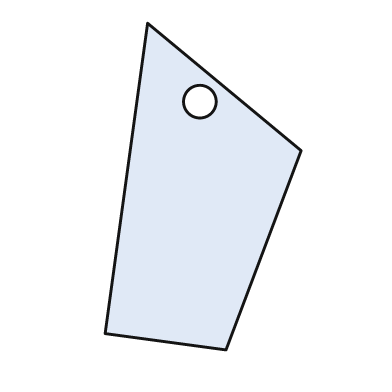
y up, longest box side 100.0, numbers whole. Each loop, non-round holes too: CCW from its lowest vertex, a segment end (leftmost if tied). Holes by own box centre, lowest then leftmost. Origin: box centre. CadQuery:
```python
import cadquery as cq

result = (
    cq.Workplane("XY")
    .moveTo(7.0, -50.0)
    .lineTo(30.0, 11.0)
    .lineTo(-17.0, 50.0)
    .lineTo(-30.0, -45.0)
    .close()
    .moveTo(-1.0, 26.0)
    .circle(5.0)
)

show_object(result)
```